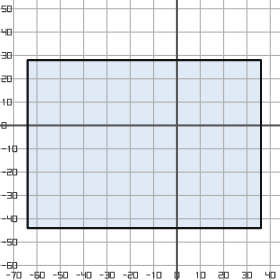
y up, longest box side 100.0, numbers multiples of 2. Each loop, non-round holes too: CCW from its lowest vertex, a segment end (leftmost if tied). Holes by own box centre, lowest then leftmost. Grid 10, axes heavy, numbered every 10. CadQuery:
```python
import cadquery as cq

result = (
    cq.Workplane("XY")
    .moveTo(-64.0, -44.0)
    .lineTo(36.0, -44.0)
    .lineTo(36.0, 28.0)
    .lineTo(-64.0, 28.0)
    .close()
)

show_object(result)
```